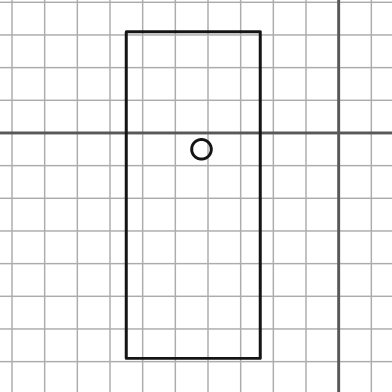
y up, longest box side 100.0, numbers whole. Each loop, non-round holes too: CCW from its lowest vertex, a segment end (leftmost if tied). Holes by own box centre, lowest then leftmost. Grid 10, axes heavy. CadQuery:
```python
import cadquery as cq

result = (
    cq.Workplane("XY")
    .moveTo(-65.0, -69.0)
    .lineTo(-24.0, -69.0)
    .lineTo(-24.0, 31.0)
    .lineTo(-65.0, 31.0)
    .close()
    .moveTo(-42.0, -5.0)
    .circle(3.0)
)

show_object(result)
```